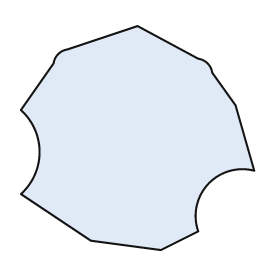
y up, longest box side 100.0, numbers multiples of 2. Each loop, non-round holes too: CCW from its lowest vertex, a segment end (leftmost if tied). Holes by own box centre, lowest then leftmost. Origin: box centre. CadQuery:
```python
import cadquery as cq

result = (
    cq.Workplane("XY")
    .moveTo(10.0, -48.0)
    .lineTo(26.0, -40.0)
    .threePointArc((30.0, -20.0), (50.0, -14.0))
    .lineTo(42.0, 14.0)
    .lineTo(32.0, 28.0)
    .threePointArc((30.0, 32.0), (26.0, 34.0))
    .lineTo(0.0, 48.0)
    .lineTo(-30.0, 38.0)
    .threePointArc((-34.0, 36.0), (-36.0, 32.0))
    .lineTo(-50.0, 12.0)
    .threePointArc((-42.0, -6.0), (-50.0, -24.0))
    .lineTo(-20.0, -44.0)
    .close()
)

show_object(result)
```